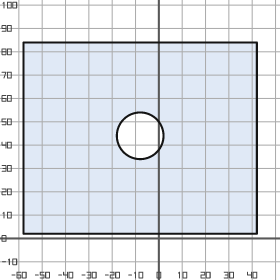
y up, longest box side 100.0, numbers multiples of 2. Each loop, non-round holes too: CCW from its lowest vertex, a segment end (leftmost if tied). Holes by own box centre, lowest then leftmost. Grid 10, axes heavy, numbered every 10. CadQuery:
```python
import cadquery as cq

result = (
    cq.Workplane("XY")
    .moveTo(-58.0, 2.0)
    .lineTo(42.0, 2.0)
    .lineTo(42.0, 84.0)
    .lineTo(-58.0, 84.0)
    .close()
    .moveTo(-8.0, 44.0)
    .circle(10.0)
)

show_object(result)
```